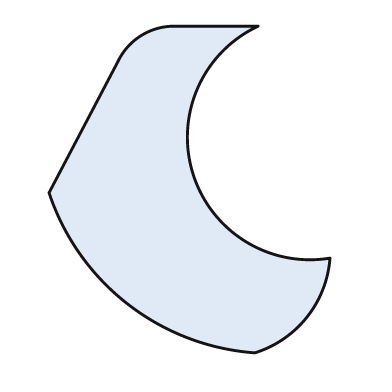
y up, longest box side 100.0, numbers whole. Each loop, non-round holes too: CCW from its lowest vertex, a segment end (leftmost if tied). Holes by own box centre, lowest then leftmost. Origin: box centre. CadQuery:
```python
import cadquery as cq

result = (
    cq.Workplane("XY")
    .moveTo(20.0, -50.0)
    .threePointArc((36.0, -39.0), (43.0, -21.0))
    .threePointArc((1.0, 5.0), (21.0, 50.0))
    .lineTo(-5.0, 50.0)
    .threePointArc((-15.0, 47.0), (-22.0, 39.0))
    .lineTo(-43.0, -1.0)
    .threePointArc((-19.0, -35.0), (20.0, -50.0))
    .close()
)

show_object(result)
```